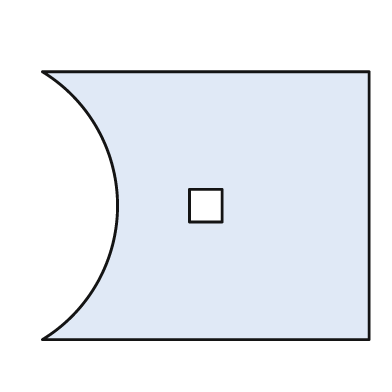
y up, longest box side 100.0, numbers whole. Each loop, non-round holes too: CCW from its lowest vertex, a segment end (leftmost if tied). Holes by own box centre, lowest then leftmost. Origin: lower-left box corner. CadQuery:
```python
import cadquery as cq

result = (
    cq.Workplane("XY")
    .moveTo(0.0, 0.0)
    .lineTo(100.0, 0.0)
    .lineTo(100.0, 82.0)
    .lineTo(0.0, 82.0)
    .threePointArc((23.0, 41.0), (0.0, 0.0))
    .close()
    .moveTo(45.0, 36.0)
    .lineTo(55.0, 36.0)
    .lineTo(55.0, 46.0)
    .lineTo(45.0, 46.0)
    .close()
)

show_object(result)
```